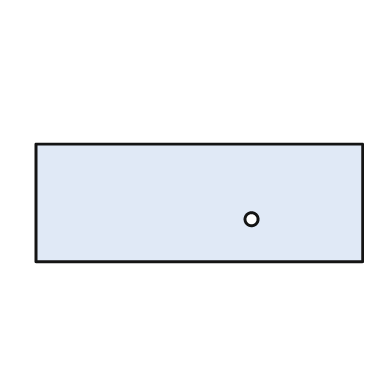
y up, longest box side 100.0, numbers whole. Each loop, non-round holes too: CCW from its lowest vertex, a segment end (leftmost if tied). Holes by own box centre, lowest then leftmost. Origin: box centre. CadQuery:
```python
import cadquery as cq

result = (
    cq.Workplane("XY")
    .moveTo(-50.0, -18.0)
    .lineTo(50.0, -18.0)
    .lineTo(50.0, 18.0)
    .lineTo(-50.0, 18.0)
    .close()
    .moveTo(16.0, -5.0)
    .circle(2.0)
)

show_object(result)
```